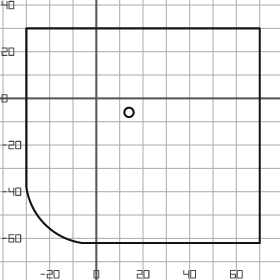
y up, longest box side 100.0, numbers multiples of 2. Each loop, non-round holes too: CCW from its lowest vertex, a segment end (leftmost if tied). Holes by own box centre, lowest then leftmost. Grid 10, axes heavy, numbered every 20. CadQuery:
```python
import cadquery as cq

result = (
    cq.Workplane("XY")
    .moveTo(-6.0, -62.0)
    .lineTo(70.0, -62.0)
    .lineTo(70.0, 30.0)
    .lineTo(-30.0, 30.0)
    .lineTo(-30.0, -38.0)
    .threePointArc((-22.0, -54.0), (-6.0, -62.0))
    .close()
    .moveTo(14.0, -6.0)
    .circle(2.0)
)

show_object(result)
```